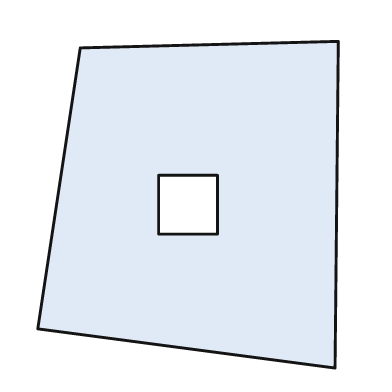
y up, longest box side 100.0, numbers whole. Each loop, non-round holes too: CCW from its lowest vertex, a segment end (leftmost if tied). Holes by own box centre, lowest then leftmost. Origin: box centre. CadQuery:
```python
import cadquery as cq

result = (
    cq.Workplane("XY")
    .moveTo(45.0, -50.0)
    .lineTo(46.0, 50.0)
    .lineTo(-33.0, 48.0)
    .lineTo(-46.0, -38.0)
    .close()
    .moveTo(-9.0, -9.0)
    .lineTo(9.0, -9.0)
    .lineTo(9.0, 9.0)
    .lineTo(-9.0, 9.0)
    .close()
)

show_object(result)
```